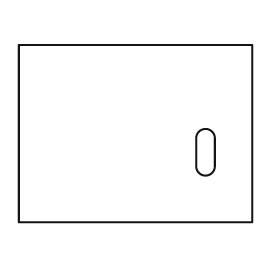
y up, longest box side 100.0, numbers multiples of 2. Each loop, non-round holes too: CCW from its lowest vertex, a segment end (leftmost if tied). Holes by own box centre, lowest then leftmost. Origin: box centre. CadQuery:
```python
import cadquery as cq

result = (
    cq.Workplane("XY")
    .moveTo(-50.0, -38.0)
    .lineTo(50.0, -38.0)
    .lineTo(50.0, 38.0)
    .lineTo(-50.0, 38.0)
    .close()
    .moveTo(26.0, -14.0)
    .threePointArc((30.0, -18.0), (34.0, -14.0))
    .lineTo(34.0, -2.0)
    .threePointArc((30.0, 2.0), (26.0, -2.0))
    .close()
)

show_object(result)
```